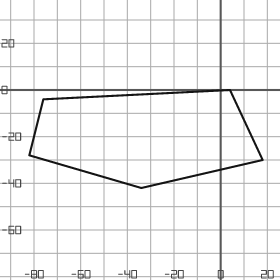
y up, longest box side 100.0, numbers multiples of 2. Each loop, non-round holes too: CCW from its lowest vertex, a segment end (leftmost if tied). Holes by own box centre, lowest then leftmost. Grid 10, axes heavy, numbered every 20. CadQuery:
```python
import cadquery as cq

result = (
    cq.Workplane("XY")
    .moveTo(-34.0, -42.0)
    .lineTo(18.0, -30.0)
    .lineTo(4.0, 0.0)
    .lineTo(-76.0, -4.0)
    .lineTo(-82.0, -28.0)
    .close()
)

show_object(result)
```